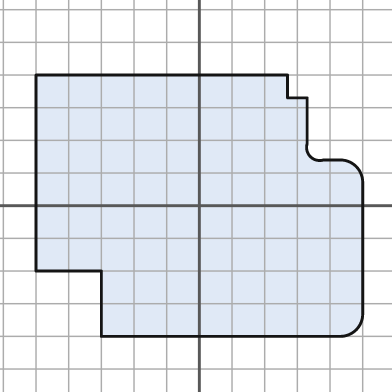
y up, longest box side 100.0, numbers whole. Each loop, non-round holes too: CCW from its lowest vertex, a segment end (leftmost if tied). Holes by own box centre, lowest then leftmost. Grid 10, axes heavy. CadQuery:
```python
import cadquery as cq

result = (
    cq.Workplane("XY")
    .moveTo(-30.0, -40.0)
    .lineTo(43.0, -40.0)
    .threePointArc((48.0, -38.0), (50.0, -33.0))
    .lineTo(50.0, 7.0)
    .threePointArc((48.0, 12.0), (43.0, 14.0))
    .lineTo(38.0, 14.0)
    .threePointArc((34.0, 15.0), (33.0, 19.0))
    .lineTo(33.0, 33.0)
    .lineTo(27.0, 33.0)
    .lineTo(27.0, 40.0)
    .lineTo(-50.0, 40.0)
    .lineTo(-50.0, -20.0)
    .lineTo(-30.0, -20.0)
    .close()
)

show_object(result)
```